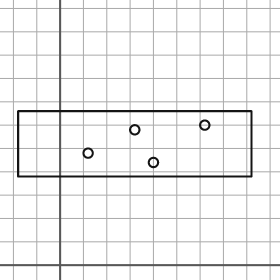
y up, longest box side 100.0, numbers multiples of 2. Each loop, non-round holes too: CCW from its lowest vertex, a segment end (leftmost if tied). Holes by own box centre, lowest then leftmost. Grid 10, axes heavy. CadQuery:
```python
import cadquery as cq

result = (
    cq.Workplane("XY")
    .moveTo(-18.0, 38.0)
    .lineTo(82.0, 38.0)
    .lineTo(82.0, 66.0)
    .lineTo(-18.0, 66.0)
    .close()
    .moveTo(40.0, 44.0)
    .circle(2.0)
    .moveTo(12.0, 48.0)
    .circle(2.0)
    .moveTo(32.0, 58.0)
    .circle(2.0)
    .moveTo(62.0, 60.0)
    .circle(2.0)
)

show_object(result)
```